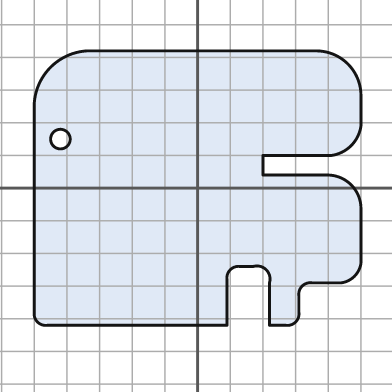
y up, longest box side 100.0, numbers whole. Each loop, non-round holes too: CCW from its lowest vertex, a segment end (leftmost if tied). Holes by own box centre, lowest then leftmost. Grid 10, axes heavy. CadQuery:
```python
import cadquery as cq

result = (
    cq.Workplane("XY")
    .moveTo(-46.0, -42.0)
    .lineTo(9.0, -42.0)
    .lineTo(9.0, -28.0)
    .threePointArc((10.0, -25.0), (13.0, -24.0))
    .lineTo(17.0, -24.0)
    .threePointArc((21.0, -25.0), (22.0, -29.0))
    .lineTo(22.0, -42.0)
    .lineTo(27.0, -42.0)
    .threePointArc((30.0, -41.0), (31.0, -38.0))
    .lineTo(31.0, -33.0)
    .threePointArc((32.0, -30.0), (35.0, -29.0))
    .lineTo(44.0, -29.0)
    .threePointArc((48.0, -27.0), (50.0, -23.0))
    .lineTo(50.0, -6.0)
    .threePointArc((47.0, 1.0), (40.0, 4.0))
    .lineTo(20.0, 4.0)
    .lineTo(20.0, 10.0)
    .lineTo(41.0, 10.0)
    .threePointArc((47.0, 13.0), (50.0, 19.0))
    .lineTo(50.0, 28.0)
    .threePointArc((46.0, 38.0), (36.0, 42.0))
    .lineTo(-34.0, 42.0)
    .threePointArc((-45.0, 37.0), (-50.0, 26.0))
    .lineTo(-50.0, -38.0)
    .threePointArc((-49.0, -41.0), (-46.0, -42.0))
    .close()
    .moveTo(-42.0, 15.0)
    .circle(3.0)
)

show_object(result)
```